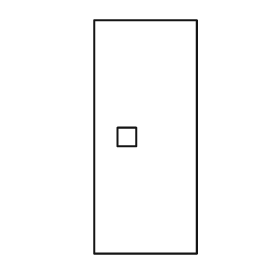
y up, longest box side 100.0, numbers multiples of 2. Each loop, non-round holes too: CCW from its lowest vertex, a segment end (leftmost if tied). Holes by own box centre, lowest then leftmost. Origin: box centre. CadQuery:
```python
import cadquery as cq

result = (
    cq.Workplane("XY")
    .moveTo(-22.0, -50.0)
    .lineTo(22.0, -50.0)
    .lineTo(22.0, 50.0)
    .lineTo(-22.0, 50.0)
    .close()
    .moveTo(-12.0, -4.0)
    .lineTo(-4.0, -4.0)
    .lineTo(-4.0, 4.0)
    .lineTo(-12.0, 4.0)
    .close()
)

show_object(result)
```